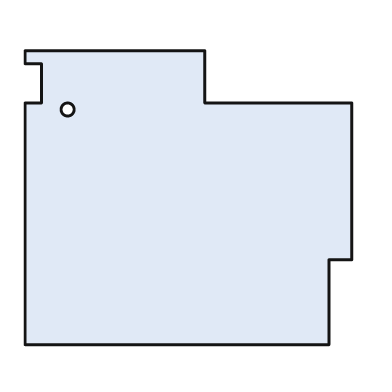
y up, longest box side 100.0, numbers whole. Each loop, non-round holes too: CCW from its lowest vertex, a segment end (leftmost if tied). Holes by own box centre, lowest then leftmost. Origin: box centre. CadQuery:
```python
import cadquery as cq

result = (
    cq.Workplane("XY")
    .moveTo(-50.0, -45.0)
    .lineTo(43.0, -45.0)
    .lineTo(43.0, -19.0)
    .lineTo(50.0, -19.0)
    .lineTo(50.0, 29.0)
    .lineTo(5.0, 29.0)
    .lineTo(5.0, 45.0)
    .lineTo(-50.0, 45.0)
    .lineTo(-50.0, 41.0)
    .lineTo(-45.0, 41.0)
    .lineTo(-45.0, 29.0)
    .lineTo(-50.0, 29.0)
    .close()
    .moveTo(-37.0, 27.0)
    .circle(2.0)
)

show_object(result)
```